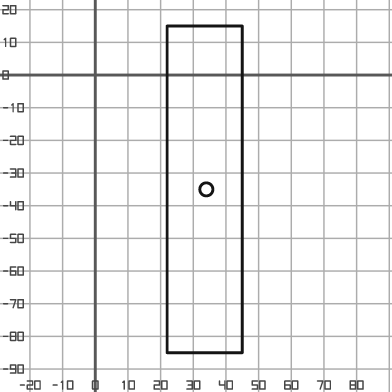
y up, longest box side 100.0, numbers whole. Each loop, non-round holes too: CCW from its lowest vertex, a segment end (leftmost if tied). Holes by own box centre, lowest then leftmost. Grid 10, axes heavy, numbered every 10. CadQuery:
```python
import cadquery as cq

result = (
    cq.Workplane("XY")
    .moveTo(22.0, -85.0)
    .lineTo(45.0, -85.0)
    .lineTo(45.0, 15.0)
    .lineTo(22.0, 15.0)
    .close()
    .moveTo(34.0, -35.0)
    .circle(2.0)
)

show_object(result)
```